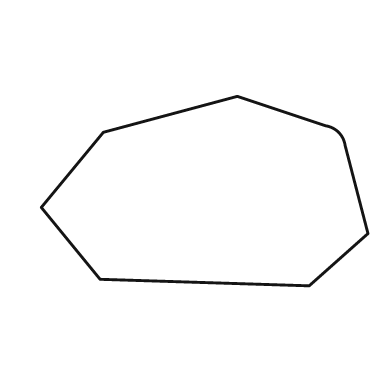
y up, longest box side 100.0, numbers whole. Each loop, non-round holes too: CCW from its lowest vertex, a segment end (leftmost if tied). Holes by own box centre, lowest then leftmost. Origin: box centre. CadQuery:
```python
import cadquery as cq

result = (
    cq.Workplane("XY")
    .moveTo(32.0, -29.0)
    .lineTo(50.0, -13.0)
    .lineTo(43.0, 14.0)
    .threePointArc((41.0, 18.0), (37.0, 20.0))
    .lineTo(10.0, 29.0)
    .lineTo(-31.0, 18.0)
    .lineTo(-50.0, -5.0)
    .lineTo(-32.0, -27.0)
    .close()
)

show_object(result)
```